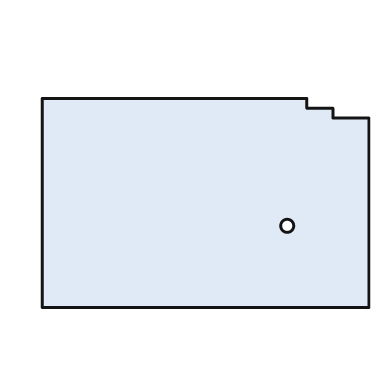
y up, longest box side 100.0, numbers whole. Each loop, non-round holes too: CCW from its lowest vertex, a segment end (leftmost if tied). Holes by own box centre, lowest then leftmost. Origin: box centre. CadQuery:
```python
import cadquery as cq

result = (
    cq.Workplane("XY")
    .moveTo(-50.0, -32.0)
    .lineTo(50.0, -32.0)
    .lineTo(50.0, 26.0)
    .lineTo(39.0, 26.0)
    .lineTo(39.0, 29.0)
    .lineTo(31.0, 29.0)
    .lineTo(31.0, 32.0)
    .lineTo(-50.0, 32.0)
    .close()
    .moveTo(25.0, -7.0)
    .circle(2.0)
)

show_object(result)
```